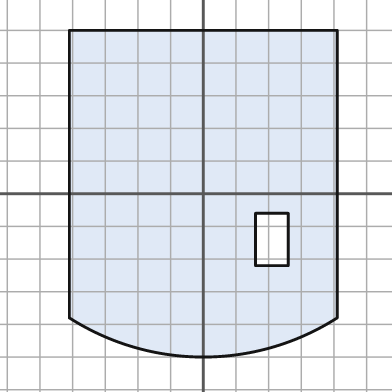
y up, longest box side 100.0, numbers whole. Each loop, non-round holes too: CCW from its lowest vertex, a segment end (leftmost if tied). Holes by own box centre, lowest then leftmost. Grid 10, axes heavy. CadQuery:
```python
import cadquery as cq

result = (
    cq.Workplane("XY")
    .moveTo(-41.0, -38.0)
    .threePointArc((0.0, -50.0), (41.0, -38.0))
    .lineTo(41.0, 50.0)
    .lineTo(-41.0, 50.0)
    .close()
    .moveTo(16.0, -22.0)
    .lineTo(26.0, -22.0)
    .lineTo(26.0, -6.0)
    .lineTo(16.0, -6.0)
    .close()
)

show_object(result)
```